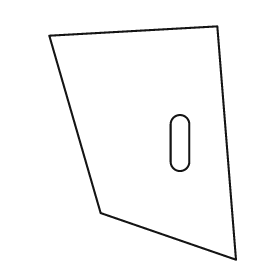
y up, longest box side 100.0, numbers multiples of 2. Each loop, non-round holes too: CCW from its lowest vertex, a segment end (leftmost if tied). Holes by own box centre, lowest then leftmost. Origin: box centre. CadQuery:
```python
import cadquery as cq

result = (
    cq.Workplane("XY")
    .moveTo(40.0, -50.0)
    .lineTo(32.0, 50.0)
    .lineTo(-40.0, 46.0)
    .lineTo(-18.0, -30.0)
    .close()
    .moveTo(12.0, -8.0)
    .threePointArc((16.0, -12.0), (20.0, -8.0))
    .lineTo(20.0, 8.0)
    .threePointArc((16.0, 12.0), (12.0, 8.0))
    .close()
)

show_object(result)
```